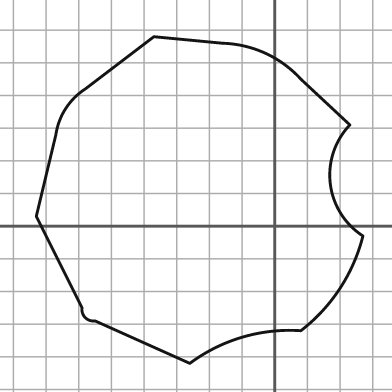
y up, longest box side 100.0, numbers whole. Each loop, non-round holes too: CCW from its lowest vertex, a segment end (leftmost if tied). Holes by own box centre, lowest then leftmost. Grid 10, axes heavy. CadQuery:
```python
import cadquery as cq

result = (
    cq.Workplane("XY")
    .moveTo(-26.0, -42.0)
    .threePointArc((-10.0, -34.0), (8.0, -32.0))
    .threePointArc((20.0, -19.0), (27.0, -3.0))
    .threePointArc((17.0, 13.0), (23.0, 31.0))
    .lineTo(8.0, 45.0)
    .threePointArc((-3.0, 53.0), (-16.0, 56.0))
    .lineTo(-37.0, 58.0)
    .lineTo(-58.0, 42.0)
    .threePointArc((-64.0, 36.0), (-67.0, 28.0))
    .lineTo(-73.0, 3.0)
    .lineTo(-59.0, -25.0)
    .threePointArc((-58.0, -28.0), (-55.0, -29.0))
    .close()
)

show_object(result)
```